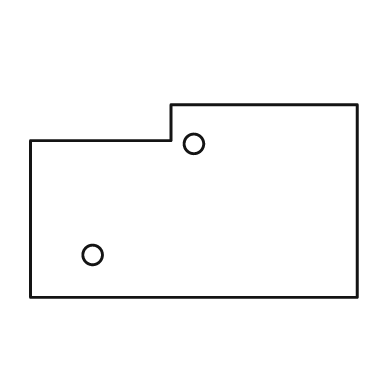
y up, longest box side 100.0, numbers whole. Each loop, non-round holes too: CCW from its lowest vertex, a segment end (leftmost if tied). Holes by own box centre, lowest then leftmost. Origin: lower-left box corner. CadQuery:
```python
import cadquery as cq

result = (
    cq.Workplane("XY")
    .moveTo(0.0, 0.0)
    .lineTo(100.0, 0.0)
    .lineTo(100.0, 59.0)
    .lineTo(43.0, 59.0)
    .lineTo(43.0, 48.0)
    .lineTo(0.0, 48.0)
    .close()
    .moveTo(19.0, 13.0)
    .circle(3.0)
    .moveTo(50.0, 47.0)
    .circle(3.0)
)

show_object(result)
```